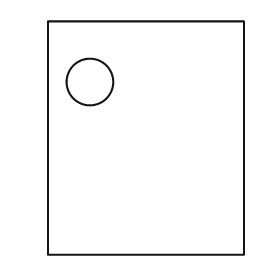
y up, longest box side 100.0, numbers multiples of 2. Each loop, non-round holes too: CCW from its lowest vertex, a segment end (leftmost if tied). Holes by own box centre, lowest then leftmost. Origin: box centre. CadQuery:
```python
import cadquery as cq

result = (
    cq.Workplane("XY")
    .moveTo(-42.0, -50.0)
    .lineTo(42.0, -50.0)
    .lineTo(42.0, 50.0)
    .lineTo(-42.0, 50.0)
    .close()
    .moveTo(-24.0, 24.0)
    .circle(10.0)
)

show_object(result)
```